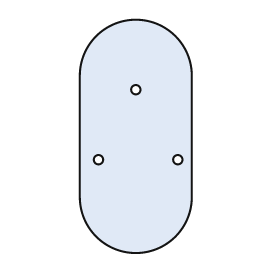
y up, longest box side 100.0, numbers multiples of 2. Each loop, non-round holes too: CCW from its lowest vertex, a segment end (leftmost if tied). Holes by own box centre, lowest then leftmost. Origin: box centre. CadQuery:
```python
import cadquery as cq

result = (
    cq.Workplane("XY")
    .moveTo(-24.0, -26.0)
    .threePointArc((0.0, -50.0), (24.0, -26.0))
    .lineTo(24.0, 26.0)
    .threePointArc((0.0, 50.0), (-24.0, 26.0))
    .close()
    .moveTo(-16.0, -10.0)
    .circle(2.0)
    .moveTo(18.0, -10.0)
    .circle(2.0)
    .moveTo(0.0, 20.0)
    .circle(2.0)
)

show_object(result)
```